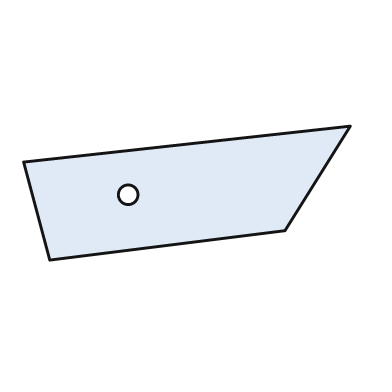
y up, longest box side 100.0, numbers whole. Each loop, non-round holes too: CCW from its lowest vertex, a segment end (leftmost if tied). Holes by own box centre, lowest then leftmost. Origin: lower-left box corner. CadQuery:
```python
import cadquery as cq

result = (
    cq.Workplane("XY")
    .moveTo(8.0, 0.0)
    .lineTo(80.0, 9.0)
    .lineTo(100.0, 41.0)
    .lineTo(0.0, 30.0)
    .close()
    .moveTo(32.0, 20.0)
    .circle(3.0)
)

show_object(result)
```